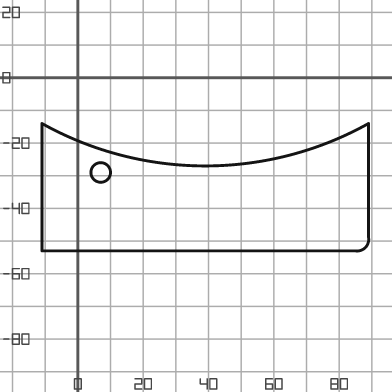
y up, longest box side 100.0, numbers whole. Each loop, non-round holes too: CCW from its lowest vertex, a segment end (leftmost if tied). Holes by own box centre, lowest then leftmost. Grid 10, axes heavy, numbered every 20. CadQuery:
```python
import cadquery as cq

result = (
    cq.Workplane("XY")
    .moveTo(-11.0, -53.0)
    .lineTo(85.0, -53.0)
    .threePointArc((88.0, -52.0), (89.0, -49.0))
    .lineTo(89.0, -14.0)
    .threePointArc((39.0, -27.0), (-11.0, -14.0))
    .close()
    .moveTo(7.0, -29.0)
    .circle(3.0)
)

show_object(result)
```